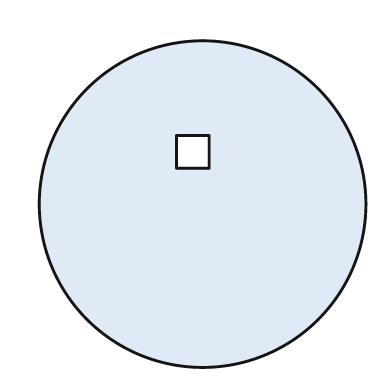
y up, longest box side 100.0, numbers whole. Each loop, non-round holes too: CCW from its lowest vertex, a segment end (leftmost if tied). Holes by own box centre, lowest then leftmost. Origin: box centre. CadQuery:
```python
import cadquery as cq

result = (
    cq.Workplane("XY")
    .moveTo(0.0, 0.0)
    .circle(50.0)
    .moveTo(-8.0, 11.0)
    .lineTo(2.0, 11.0)
    .lineTo(2.0, 21.0)
    .lineTo(-8.0, 21.0)
    .close()
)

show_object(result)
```